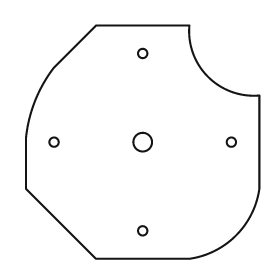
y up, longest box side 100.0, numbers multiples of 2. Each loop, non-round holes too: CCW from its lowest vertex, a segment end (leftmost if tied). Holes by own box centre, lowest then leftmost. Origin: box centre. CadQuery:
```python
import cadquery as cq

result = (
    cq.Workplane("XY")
    .moveTo(-20.0, -50.0)
    .lineTo(20.0, -50.0)
    .threePointArc((40.0, -40.0), (50.0, -20.0))
    .lineTo(50.0, 20.0)
    .threePointArc((28.0, 28.0), (20.0, 50.0))
    .lineTo(-20.0, 50.0)
    .lineTo(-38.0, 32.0)
    .threePointArc((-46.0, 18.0), (-50.0, 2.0))
    .lineTo(-50.0, -20.0)
    .close()
    .moveTo(0.0, -38.0)
    .circle(2.0)
    .moveTo(-38.0, 0.0)
    .circle(2.0)
    .moveTo(0.0, 0.0)
    .circle(4.0)
    .moveTo(38.0, 0.0)
    .circle(2.0)
    .moveTo(0.0, 38.0)
    .circle(2.0)
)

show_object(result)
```